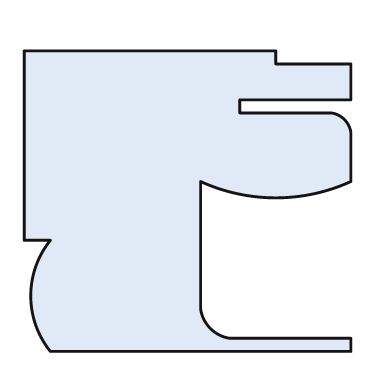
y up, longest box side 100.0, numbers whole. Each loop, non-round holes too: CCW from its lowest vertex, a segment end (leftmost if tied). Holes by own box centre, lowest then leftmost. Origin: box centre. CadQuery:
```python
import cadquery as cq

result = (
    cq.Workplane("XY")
    .moveTo(-42.0, -46.0)
    .lineTo(50.0, -46.0)
    .lineTo(50.0, -42.0)
    .lineTo(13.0, -42.0)
    .threePointArc((7.0, -39.0), (4.0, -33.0))
    .lineTo(4.0, 6.0)
    .threePointArc((27.0, 1.0), (50.0, 6.0))
    .lineTo(50.0, 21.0)
    .threePointArc((48.0, 25.0), (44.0, 27.0))
    .lineTo(16.0, 27.0)
    .lineTo(16.0, 31.0)
    .lineTo(50.0, 31.0)
    .lineTo(50.0, 42.0)
    .lineTo(27.0, 42.0)
    .lineTo(27.0, 46.0)
    .lineTo(-50.0, 46.0)
    .lineTo(-50.0, -12.0)
    .lineTo(-42.0, -12.0)
    .threePointArc((-48.0, -29.0), (-42.0, -46.0))
    .close()
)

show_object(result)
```